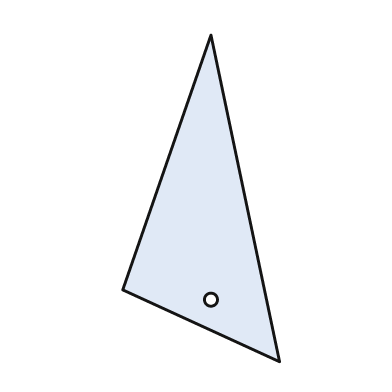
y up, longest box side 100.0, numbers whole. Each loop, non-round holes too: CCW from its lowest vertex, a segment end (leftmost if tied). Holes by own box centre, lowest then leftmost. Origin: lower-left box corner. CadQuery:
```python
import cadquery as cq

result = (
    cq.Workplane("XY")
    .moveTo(48.0, 0.0)
    .lineTo(27.0, 100.0)
    .lineTo(0.0, 22.0)
    .close()
    .moveTo(27.0, 19.0)
    .circle(2.0)
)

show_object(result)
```